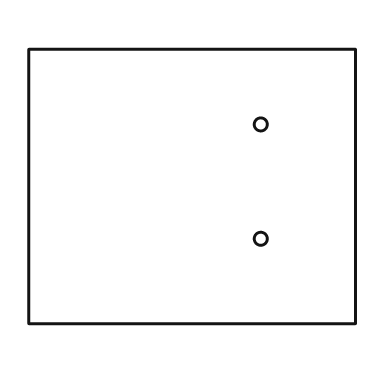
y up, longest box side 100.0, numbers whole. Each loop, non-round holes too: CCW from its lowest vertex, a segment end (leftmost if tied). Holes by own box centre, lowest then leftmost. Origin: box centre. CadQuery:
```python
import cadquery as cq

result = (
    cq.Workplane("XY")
    .moveTo(-50.0, -42.0)
    .lineTo(50.0, -42.0)
    .lineTo(50.0, 42.0)
    .lineTo(-50.0, 42.0)
    .close()
    .moveTo(21.0, -16.0)
    .circle(2.0)
    .moveTo(21.0, 19.0)
    .circle(2.0)
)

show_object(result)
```